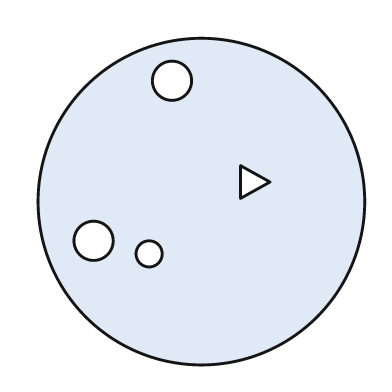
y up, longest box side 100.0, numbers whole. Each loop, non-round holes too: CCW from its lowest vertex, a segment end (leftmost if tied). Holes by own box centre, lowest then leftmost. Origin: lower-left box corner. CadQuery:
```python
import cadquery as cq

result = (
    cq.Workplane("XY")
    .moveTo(50.0, 50.0)
    .circle(50.0)
    .moveTo(34.0, 34.0)
    .circle(4.0)
    .moveTo(17.0, 38.0)
    .circle(6.0)
    .moveTo(62.0, 51.0)
    .lineTo(71.0, 56.0)
    .lineTo(62.0, 61.0)
    .close()
    .moveTo(41.0, 87.0)
    .circle(6.0)
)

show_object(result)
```